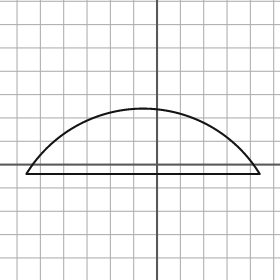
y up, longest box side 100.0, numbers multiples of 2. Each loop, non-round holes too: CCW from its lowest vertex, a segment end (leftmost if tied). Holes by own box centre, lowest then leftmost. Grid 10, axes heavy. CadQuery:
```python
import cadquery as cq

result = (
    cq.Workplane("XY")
    .moveTo(-56.0, -4.0)
    .lineTo(44.0, -4.0)
    .threePointArc((-6.0, 24.0), (-56.0, -4.0))
    .close()
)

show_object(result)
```